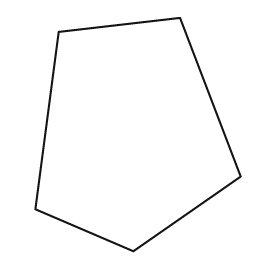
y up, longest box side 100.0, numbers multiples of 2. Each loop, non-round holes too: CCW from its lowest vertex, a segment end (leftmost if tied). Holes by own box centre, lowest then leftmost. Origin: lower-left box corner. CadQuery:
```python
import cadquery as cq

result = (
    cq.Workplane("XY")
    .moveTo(42.0, 0.0)
    .lineTo(88.0, 32.0)
    .lineTo(62.0, 100.0)
    .lineTo(10.0, 94.0)
    .lineTo(0.0, 18.0)
    .close()
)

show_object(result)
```